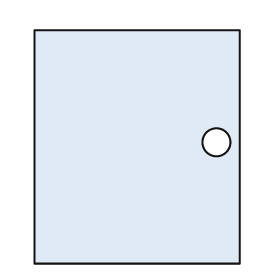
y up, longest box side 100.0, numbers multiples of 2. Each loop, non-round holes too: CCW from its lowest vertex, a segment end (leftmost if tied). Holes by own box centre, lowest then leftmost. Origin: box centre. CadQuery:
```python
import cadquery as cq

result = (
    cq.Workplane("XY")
    .moveTo(-44.0, -50.0)
    .lineTo(44.0, -50.0)
    .lineTo(44.0, 50.0)
    .lineTo(-44.0, 50.0)
    .close()
    .moveTo(34.0, 2.0)
    .circle(6.0)
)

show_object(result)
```